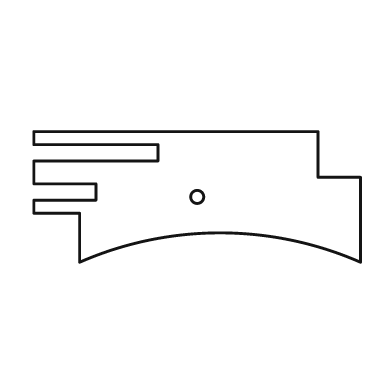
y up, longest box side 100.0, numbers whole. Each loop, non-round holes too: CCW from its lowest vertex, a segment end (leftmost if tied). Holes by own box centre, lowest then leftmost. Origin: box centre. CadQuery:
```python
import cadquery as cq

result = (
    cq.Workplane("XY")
    .moveTo(-36.0, -20.0)
    .threePointArc((7.0, -11.0), (50.0, -20.0))
    .lineTo(50.0, 6.0)
    .lineTo(37.0, 6.0)
    .lineTo(37.0, 20.0)
    .lineTo(-50.0, 20.0)
    .lineTo(-50.0, 16.0)
    .lineTo(-12.0, 16.0)
    .lineTo(-12.0, 11.0)
    .lineTo(-50.0, 11.0)
    .lineTo(-50.0, 4.0)
    .lineTo(-31.0, 4.0)
    .lineTo(-31.0, -1.0)
    .lineTo(-50.0, -1.0)
    .lineTo(-50.0, -5.0)
    .lineTo(-36.0, -5.0)
    .close()
    .moveTo(0.0, 0.0)
    .circle(2.0)
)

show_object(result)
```